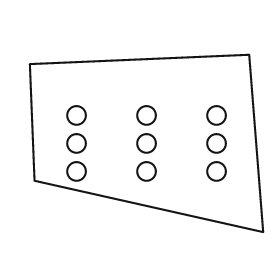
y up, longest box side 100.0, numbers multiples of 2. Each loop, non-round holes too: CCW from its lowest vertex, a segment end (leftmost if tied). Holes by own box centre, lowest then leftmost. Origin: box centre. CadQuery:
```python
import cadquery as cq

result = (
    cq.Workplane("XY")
    .moveTo(50.0, -38.0)
    .lineTo(44.0, 38.0)
    .lineTo(-50.0, 34.0)
    .lineTo(-48.0, -16.0)
    .close()
    .moveTo(-30.0, -12.0)
    .circle(4.0)
    .moveTo(0.0, -12.0)
    .circle(4.0)
    .moveTo(30.0, -12.0)
    .circle(4.0)
    .moveTo(-30.0, 0.0)
    .circle(4.0)
    .moveTo(0.0, 0.0)
    .circle(4.0)
    .moveTo(30.0, 0.0)
    .circle(4.0)
    .moveTo(-30.0, 12.0)
    .circle(4.0)
    .moveTo(0.0, 12.0)
    .circle(4.0)
    .moveTo(30.0, 12.0)
    .circle(4.0)
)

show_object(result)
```